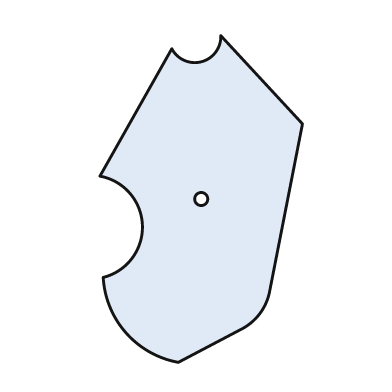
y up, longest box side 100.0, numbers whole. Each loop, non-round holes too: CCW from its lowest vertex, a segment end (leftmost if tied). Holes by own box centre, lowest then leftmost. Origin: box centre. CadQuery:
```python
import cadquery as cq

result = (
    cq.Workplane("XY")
    .moveTo(-7.0, -50.0)
    .lineTo(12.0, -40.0)
    .threePointArc((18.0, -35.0), (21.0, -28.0))
    .lineTo(31.0, 23.0)
    .lineTo(6.0, 50.0)
    .threePointArc((0.0, 42.0), (-9.0, 46.0))
    .lineTo(-31.0, 7.0)
    .threePointArc((-18.0, -8.0), (-30.0, -24.0))
    .threePointArc((-23.0, -41.0), (-7.0, -50.0))
    .close()
    .moveTo(0.0, 0.0)
    .circle(2.0)
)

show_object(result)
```